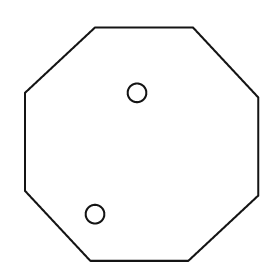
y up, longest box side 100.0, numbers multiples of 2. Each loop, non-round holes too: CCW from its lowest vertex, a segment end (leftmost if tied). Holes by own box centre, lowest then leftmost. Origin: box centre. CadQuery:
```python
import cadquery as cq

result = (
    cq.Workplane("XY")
    .moveTo(-22.0, -50.0)
    .lineTo(20.0, -50.0)
    .lineTo(50.0, -22.0)
    .lineTo(50.0, 20.0)
    .lineTo(22.0, 50.0)
    .lineTo(-20.0, 50.0)
    .lineTo(-50.0, 22.0)
    .lineTo(-50.0, -20.0)
    .close()
    .moveTo(-20.0, -30.0)
    .circle(4.0)
    .moveTo(-2.0, 22.0)
    .circle(4.0)
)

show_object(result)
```